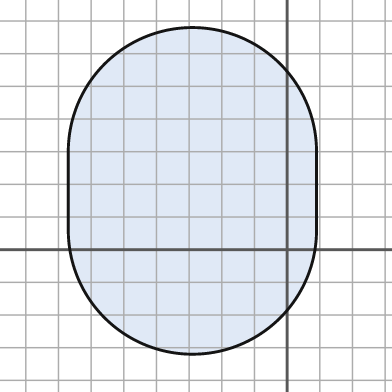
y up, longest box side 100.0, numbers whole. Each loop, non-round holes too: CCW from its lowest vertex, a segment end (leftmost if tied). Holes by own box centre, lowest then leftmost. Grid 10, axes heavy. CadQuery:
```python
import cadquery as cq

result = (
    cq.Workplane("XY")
    .moveTo(-67.0, 6.0)
    .threePointArc((-29.0, -32.0), (9.0, 6.0))
    .lineTo(9.0, 30.0)
    .threePointArc((-29.0, 68.0), (-67.0, 30.0))
    .close()
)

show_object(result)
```